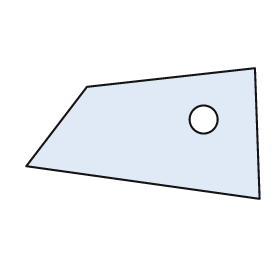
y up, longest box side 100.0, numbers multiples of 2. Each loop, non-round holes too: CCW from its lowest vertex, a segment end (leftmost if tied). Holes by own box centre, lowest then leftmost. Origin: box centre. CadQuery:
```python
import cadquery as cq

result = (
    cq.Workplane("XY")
    .moveTo(50.0, -28.0)
    .lineTo(48.0, 28.0)
    .lineTo(-24.0, 20.0)
    .lineTo(-50.0, -14.0)
    .close()
    .moveTo(26.0, 6.0)
    .circle(6.0)
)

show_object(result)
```